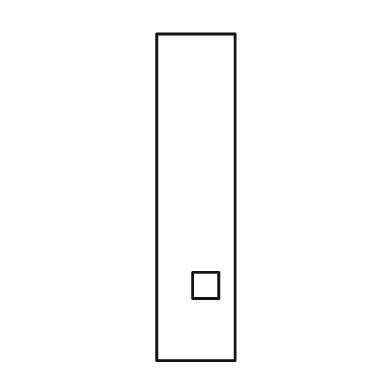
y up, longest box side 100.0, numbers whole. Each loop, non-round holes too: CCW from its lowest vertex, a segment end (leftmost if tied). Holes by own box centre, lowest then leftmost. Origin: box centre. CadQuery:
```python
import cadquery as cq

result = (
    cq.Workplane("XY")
    .moveTo(-12.0, -50.0)
    .lineTo(12.0, -50.0)
    .lineTo(12.0, 50.0)
    .lineTo(-12.0, 50.0)
    .close()
    .moveTo(-1.0, -31.0)
    .lineTo(7.0, -31.0)
    .lineTo(7.0, -23.0)
    .lineTo(-1.0, -23.0)
    .close()
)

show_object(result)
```